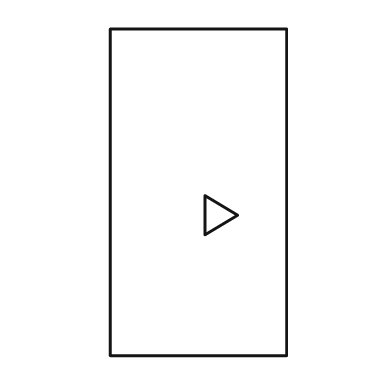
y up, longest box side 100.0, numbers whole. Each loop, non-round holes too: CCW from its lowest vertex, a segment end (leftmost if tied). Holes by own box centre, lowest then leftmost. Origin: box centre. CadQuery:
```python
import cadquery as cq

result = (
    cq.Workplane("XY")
    .moveTo(-27.0, -50.0)
    .lineTo(27.0, -50.0)
    .lineTo(27.0, 50.0)
    .lineTo(-27.0, 50.0)
    .close()
    .moveTo(2.0, -13.0)
    .lineTo(12.0, -7.0)
    .lineTo(2.0, -1.0)
    .close()
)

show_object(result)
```